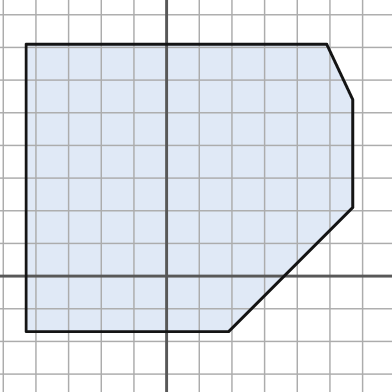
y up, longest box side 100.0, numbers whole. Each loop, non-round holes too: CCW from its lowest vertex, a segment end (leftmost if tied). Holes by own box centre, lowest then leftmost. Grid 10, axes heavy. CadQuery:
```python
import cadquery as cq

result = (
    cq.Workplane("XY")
    .moveTo(-43.0, -17.0)
    .lineTo(19.0, -17.0)
    .lineTo(57.0, 21.0)
    .lineTo(57.0, 54.0)
    .lineTo(49.0, 71.0)
    .lineTo(-43.0, 71.0)
    .close()
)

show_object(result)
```